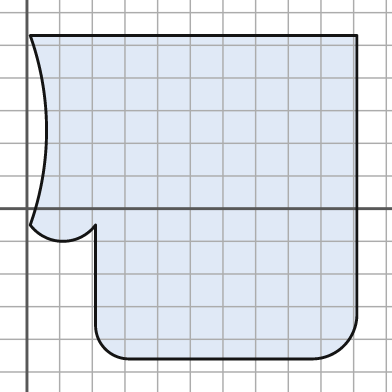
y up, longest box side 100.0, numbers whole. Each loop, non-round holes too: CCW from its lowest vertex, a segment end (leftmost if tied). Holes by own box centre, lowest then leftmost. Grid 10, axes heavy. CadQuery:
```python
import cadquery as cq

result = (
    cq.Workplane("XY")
    .moveTo(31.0, -46.0)
    .lineTo(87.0, -46.0)
    .threePointArc((97.0, -42.0), (101.0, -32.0))
    .lineTo(101.0, 53.0)
    .lineTo(1.0, 53.0)
    .threePointArc((6.0, 24.0), (1.0, -5.0))
    .threePointArc((11.0, -10.0), (21.0, -5.0))
    .lineTo(21.0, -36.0)
    .threePointArc((24.0, -43.0), (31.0, -46.0))
    .close()
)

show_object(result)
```